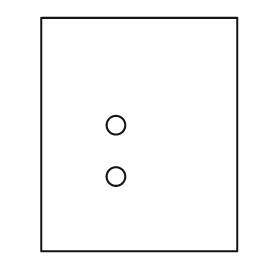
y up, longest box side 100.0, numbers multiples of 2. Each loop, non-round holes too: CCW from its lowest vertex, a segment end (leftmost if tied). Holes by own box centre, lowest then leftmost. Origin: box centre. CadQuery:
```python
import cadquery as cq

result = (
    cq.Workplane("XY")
    .moveTo(-42.0, -50.0)
    .lineTo(42.0, -50.0)
    .lineTo(42.0, 50.0)
    .lineTo(-42.0, 50.0)
    .close()
    .moveTo(-10.0, -18.0)
    .circle(4.0)
    .moveTo(-10.0, 4.0)
    .circle(4.0)
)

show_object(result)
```